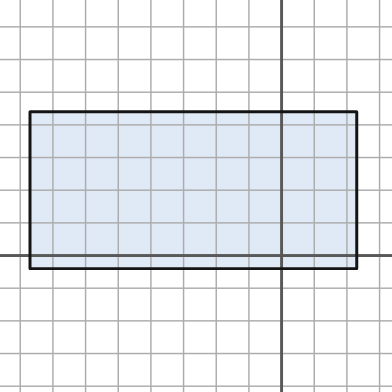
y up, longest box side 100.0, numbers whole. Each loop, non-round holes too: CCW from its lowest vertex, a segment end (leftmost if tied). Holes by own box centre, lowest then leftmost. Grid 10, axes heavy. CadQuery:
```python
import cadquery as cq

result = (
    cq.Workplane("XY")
    .moveTo(-77.0, -4.0)
    .lineTo(23.0, -4.0)
    .lineTo(23.0, 44.0)
    .lineTo(-77.0, 44.0)
    .close()
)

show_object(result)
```